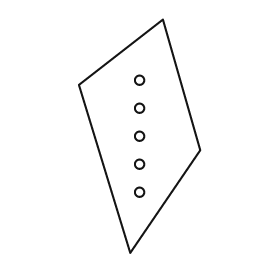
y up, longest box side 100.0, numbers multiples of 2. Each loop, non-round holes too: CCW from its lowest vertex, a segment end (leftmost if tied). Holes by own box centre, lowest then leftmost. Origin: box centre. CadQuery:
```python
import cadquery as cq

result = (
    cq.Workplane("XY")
    .moveTo(-4.0, -50.0)
    .lineTo(26.0, -6.0)
    .lineTo(10.0, 50.0)
    .lineTo(-26.0, 22.0)
    .close()
    .moveTo(0.0, -24.0)
    .circle(2.0)
    .moveTo(0.0, -12.0)
    .circle(2.0)
    .moveTo(0.0, 0.0)
    .circle(2.0)
    .moveTo(0.0, 12.0)
    .circle(2.0)
    .moveTo(0.0, 24.0)
    .circle(2.0)
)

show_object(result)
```